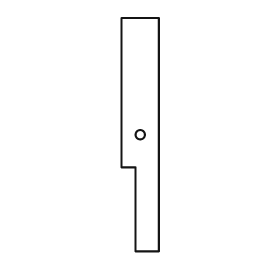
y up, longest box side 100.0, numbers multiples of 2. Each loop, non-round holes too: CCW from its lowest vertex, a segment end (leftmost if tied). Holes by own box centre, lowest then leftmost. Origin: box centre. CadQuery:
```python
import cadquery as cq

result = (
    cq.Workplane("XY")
    .moveTo(-2.0, -50.0)
    .lineTo(8.0, -50.0)
    .lineTo(8.0, 50.0)
    .lineTo(-8.0, 50.0)
    .lineTo(-8.0, -14.0)
    .lineTo(-2.0, -14.0)
    .close()
    .moveTo(0.0, 0.0)
    .circle(2.0)
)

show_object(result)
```